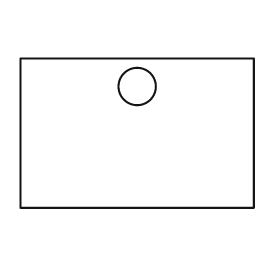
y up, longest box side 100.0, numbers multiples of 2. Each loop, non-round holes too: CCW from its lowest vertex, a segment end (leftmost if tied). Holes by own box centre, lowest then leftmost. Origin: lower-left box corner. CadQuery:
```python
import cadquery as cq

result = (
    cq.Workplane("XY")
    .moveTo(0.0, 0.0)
    .lineTo(100.0, 0.0)
    .lineTo(100.0, 64.0)
    .lineTo(0.0, 64.0)
    .close()
    .moveTo(50.0, 52.0)
    .circle(8.0)
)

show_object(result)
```